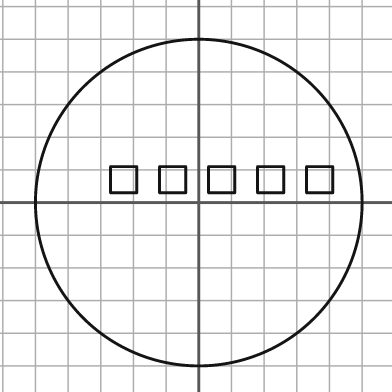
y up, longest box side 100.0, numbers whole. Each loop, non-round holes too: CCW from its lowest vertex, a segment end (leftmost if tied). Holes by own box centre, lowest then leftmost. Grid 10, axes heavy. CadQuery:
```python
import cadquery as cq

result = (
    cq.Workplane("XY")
    .moveTo(0.0, 0.0)
    .circle(50.0)
    .moveTo(-27.0, 3.0)
    .lineTo(-19.0, 3.0)
    .lineTo(-19.0, 11.0)
    .lineTo(-27.0, 11.0)
    .close()
    .moveTo(-12.0, 3.0)
    .lineTo(-4.0, 3.0)
    .lineTo(-4.0, 11.0)
    .lineTo(-12.0, 11.0)
    .close()
    .moveTo(3.0, 3.0)
    .lineTo(11.0, 3.0)
    .lineTo(11.0, 11.0)
    .lineTo(3.0, 11.0)
    .close()
    .moveTo(18.0, 3.0)
    .lineTo(26.0, 3.0)
    .lineTo(26.0, 11.0)
    .lineTo(18.0, 11.0)
    .close()
    .moveTo(33.0, 3.0)
    .lineTo(41.0, 3.0)
    .lineTo(41.0, 11.0)
    .lineTo(33.0, 11.0)
    .close()
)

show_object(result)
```